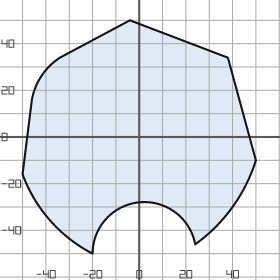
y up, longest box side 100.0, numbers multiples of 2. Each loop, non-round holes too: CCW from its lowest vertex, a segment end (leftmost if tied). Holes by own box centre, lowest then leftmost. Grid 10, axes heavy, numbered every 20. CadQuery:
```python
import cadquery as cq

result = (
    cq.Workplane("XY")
    .moveTo(-20.0, -50.0)
    .threePointArc((0.0, -28.0), (24.0, -46.0))
    .threePointArc((40.0, -30.0), (50.0, -10.0))
    .lineTo(38.0, 34.0)
    .lineTo(-4.0, 50.0)
    .lineTo(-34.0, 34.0)
    .threePointArc((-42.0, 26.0), (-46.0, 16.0))
    .lineTo(-50.0, -16.0)
    .threePointArc((-38.0, -36.0), (-20.0, -50.0))
    .close()
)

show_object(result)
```